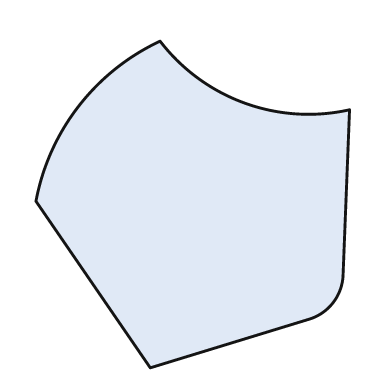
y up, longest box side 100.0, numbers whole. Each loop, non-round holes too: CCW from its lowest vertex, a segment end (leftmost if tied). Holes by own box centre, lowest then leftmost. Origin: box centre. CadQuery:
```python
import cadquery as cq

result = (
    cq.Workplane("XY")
    .moveTo(-13.0, -50.0)
    .lineTo(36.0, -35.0)
    .threePointArc((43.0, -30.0), (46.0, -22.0))
    .lineTo(48.0, 29.0)
    .threePointArc((16.0, 31.0), (-10.0, 50.0))
    .threePointArc((-35.0, 30.0), (-48.0, 1.0))
    .close()
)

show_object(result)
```